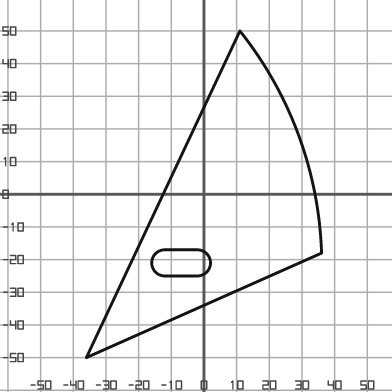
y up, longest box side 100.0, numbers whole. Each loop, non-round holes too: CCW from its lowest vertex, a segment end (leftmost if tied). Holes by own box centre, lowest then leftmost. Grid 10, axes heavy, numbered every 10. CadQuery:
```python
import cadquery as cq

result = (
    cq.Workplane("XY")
    .moveTo(-36.0, -50.0)
    .lineTo(36.0, -18.0)
    .threePointArc((29.0, 18.0), (11.0, 50.0))
    .close()
    .moveTo(-12.0, -25.0)
    .lineTo(-2.0, -25.0)
    .threePointArc((2.0, -21.0), (-2.0, -17.0))
    .lineTo(-12.0, -17.0)
    .threePointArc((-16.0, -21.0), (-12.0, -25.0))
    .close()
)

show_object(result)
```